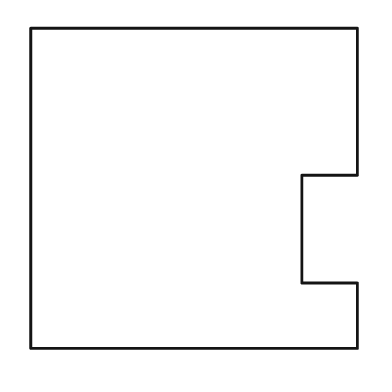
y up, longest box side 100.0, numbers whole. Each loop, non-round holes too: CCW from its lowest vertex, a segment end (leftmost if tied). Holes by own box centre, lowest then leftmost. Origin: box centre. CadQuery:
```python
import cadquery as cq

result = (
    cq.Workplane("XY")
    .moveTo(-50.0, -49.0)
    .lineTo(50.0, -49.0)
    .lineTo(50.0, -29.0)
    .lineTo(33.0, -29.0)
    .lineTo(33.0, 4.0)
    .lineTo(50.0, 4.0)
    .lineTo(50.0, 49.0)
    .lineTo(-50.0, 49.0)
    .close()
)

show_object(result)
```